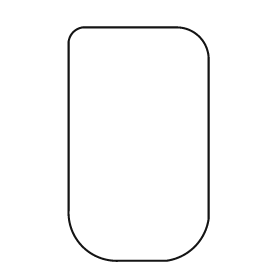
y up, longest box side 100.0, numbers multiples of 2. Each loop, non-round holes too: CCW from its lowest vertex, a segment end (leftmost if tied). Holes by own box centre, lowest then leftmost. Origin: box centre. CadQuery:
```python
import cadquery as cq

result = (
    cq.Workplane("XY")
    .moveTo(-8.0, -50.0)
    .lineTo(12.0, -50.0)
    .threePointArc((24.0, -44.0), (30.0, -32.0))
    .lineTo(30.0, 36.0)
    .threePointArc((26.0, 46.0), (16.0, 50.0))
    .lineTo(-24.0, 50.0)
    .threePointArc((-28.0, 48.0), (-30.0, 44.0))
    .lineTo(-30.0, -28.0)
    .threePointArc((-24.0, -44.0), (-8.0, -50.0))
    .close()
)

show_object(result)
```